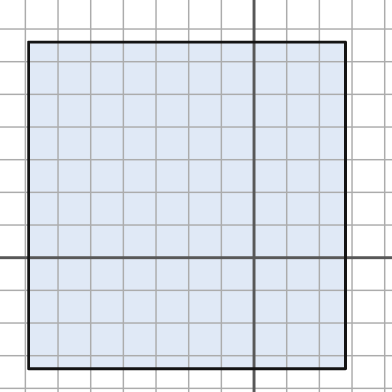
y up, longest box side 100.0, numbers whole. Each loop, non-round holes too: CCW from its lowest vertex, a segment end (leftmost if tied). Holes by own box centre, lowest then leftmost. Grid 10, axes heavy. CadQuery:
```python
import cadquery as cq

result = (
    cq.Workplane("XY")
    .moveTo(-69.0, -34.0)
    .lineTo(28.0, -34.0)
    .lineTo(28.0, 66.0)
    .lineTo(-69.0, 66.0)
    .close()
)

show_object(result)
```